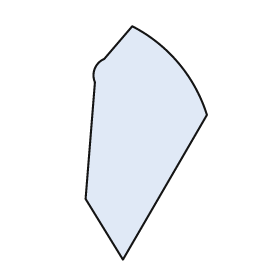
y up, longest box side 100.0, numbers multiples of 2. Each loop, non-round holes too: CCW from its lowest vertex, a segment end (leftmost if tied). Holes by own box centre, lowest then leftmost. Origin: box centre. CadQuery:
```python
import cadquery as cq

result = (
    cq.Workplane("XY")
    .moveTo(-10.0, -50.0)
    .lineTo(26.0, 12.0)
    .threePointArc((14.0, 34.0), (-6.0, 50.0))
    .lineTo(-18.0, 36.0)
    .threePointArc((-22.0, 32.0), (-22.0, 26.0))
    .lineTo(-26.0, -24.0)
    .close()
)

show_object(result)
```